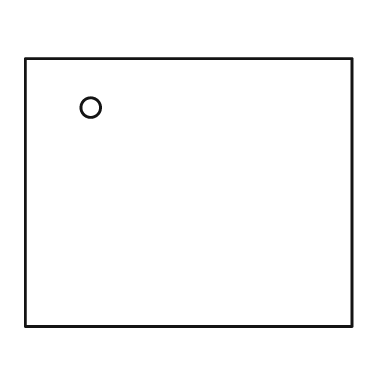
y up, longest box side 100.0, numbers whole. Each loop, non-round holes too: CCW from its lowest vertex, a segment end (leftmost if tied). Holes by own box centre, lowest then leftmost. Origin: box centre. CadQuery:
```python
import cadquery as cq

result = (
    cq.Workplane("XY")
    .moveTo(-50.0, -41.0)
    .lineTo(50.0, -41.0)
    .lineTo(50.0, 41.0)
    .lineTo(-50.0, 41.0)
    .close()
    .moveTo(-30.0, 26.0)
    .circle(3.0)
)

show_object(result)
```